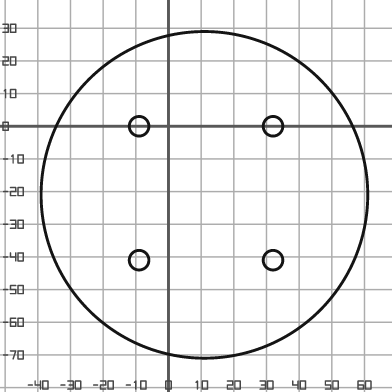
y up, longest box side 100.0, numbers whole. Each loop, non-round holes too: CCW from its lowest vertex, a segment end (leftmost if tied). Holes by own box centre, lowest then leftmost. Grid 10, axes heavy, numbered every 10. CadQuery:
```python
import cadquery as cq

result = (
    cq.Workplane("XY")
    .moveTo(11.0, -21.0)
    .circle(50.0)
    .moveTo(-9.0, -41.0)
    .circle(3.0)
    .moveTo(32.0, -41.0)
    .circle(3.0)
    .moveTo(-9.0, 0.0)
    .circle(3.0)
    .moveTo(32.0, 0.0)
    .circle(3.0)
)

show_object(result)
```